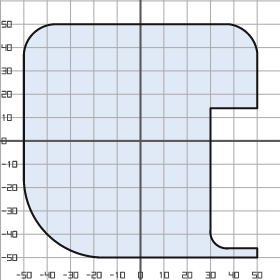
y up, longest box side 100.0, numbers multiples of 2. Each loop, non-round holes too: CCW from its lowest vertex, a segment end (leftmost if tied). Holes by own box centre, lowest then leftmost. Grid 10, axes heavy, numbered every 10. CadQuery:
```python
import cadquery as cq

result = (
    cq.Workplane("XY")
    .moveTo(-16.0, -50.0)
    .lineTo(50.0, -50.0)
    .lineTo(50.0, -46.0)
    .lineTo(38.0, -46.0)
    .threePointArc((32.0, -44.0), (30.0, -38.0))
    .lineTo(30.0, 14.0)
    .lineTo(50.0, 14.0)
    .lineTo(50.0, 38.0)
    .threePointArc((46.0, 46.0), (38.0, 50.0))
    .lineTo(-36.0, 50.0)
    .threePointArc((-46.0, 46.0), (-50.0, 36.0))
    .lineTo(-50.0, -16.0)
    .threePointArc((-40.0, -40.0), (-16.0, -50.0))
    .close()
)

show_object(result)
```